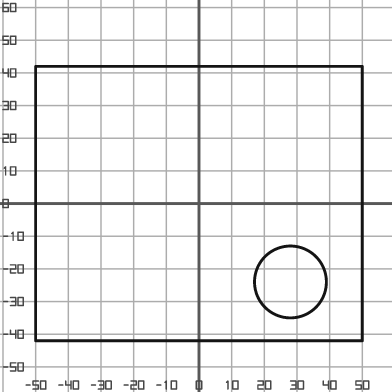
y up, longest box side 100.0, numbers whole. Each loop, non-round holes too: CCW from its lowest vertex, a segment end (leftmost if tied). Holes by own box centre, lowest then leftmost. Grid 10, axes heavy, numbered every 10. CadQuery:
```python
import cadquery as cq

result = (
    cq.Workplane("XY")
    .moveTo(-50.0, -42.0)
    .lineTo(50.0, -42.0)
    .lineTo(50.0, 42.0)
    .lineTo(-50.0, 42.0)
    .close()
    .moveTo(28.0, -24.0)
    .circle(11.0)
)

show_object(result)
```